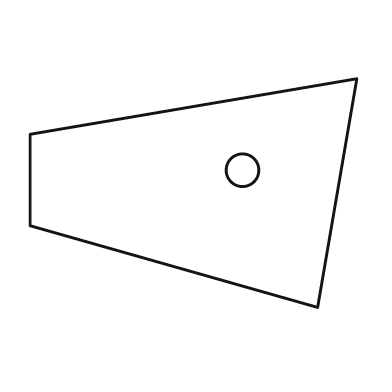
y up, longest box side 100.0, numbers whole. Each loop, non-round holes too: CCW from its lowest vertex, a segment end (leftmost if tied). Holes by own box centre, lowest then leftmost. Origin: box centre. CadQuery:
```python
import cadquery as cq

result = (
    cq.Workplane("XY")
    .moveTo(38.0, -35.0)
    .lineTo(50.0, 35.0)
    .lineTo(-50.0, 18.0)
    .lineTo(-50.0, -10.0)
    .close()
    .moveTo(15.0, 7.0)
    .circle(5.0)
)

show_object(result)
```